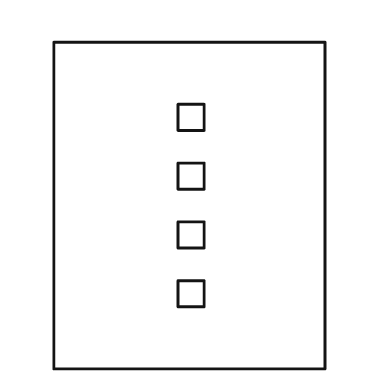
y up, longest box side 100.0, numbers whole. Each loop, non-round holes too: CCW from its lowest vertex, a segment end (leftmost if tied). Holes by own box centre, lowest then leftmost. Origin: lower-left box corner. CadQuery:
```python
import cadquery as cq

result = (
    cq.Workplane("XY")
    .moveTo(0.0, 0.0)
    .lineTo(83.0, 0.0)
    .lineTo(83.0, 100.0)
    .lineTo(0.0, 100.0)
    .close()
    .moveTo(38.0, 19.0)
    .lineTo(46.0, 19.0)
    .lineTo(46.0, 27.0)
    .lineTo(38.0, 27.0)
    .close()
    .moveTo(38.0, 37.0)
    .lineTo(46.0, 37.0)
    .lineTo(46.0, 45.0)
    .lineTo(38.0, 45.0)
    .close()
    .moveTo(38.0, 55.0)
    .lineTo(46.0, 55.0)
    .lineTo(46.0, 63.0)
    .lineTo(38.0, 63.0)
    .close()
    .moveTo(38.0, 73.0)
    .lineTo(46.0, 73.0)
    .lineTo(46.0, 81.0)
    .lineTo(38.0, 81.0)
    .close()
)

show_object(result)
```